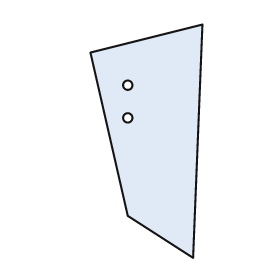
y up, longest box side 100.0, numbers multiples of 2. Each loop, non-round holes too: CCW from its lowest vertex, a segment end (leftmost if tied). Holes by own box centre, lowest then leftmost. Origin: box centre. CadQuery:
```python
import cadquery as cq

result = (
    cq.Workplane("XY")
    .moveTo(20.0, -50.0)
    .lineTo(24.0, 50.0)
    .lineTo(-24.0, 38.0)
    .lineTo(-8.0, -32.0)
    .close()
    .moveTo(-8.0, 10.0)
    .circle(2.0)
    .moveTo(-8.0, 24.0)
    .circle(2.0)
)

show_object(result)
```